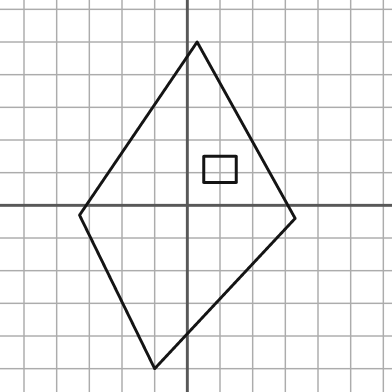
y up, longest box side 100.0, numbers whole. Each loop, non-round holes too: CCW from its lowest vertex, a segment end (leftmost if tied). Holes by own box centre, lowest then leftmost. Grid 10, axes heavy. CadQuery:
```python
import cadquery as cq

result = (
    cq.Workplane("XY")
    .moveTo(-10.0, -50.0)
    .lineTo(33.0, -4.0)
    .lineTo(3.0, 50.0)
    .lineTo(-33.0, -3.0)
    .close()
    .moveTo(5.0, 7.0)
    .lineTo(15.0, 7.0)
    .lineTo(15.0, 15.0)
    .lineTo(5.0, 15.0)
    .close()
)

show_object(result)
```